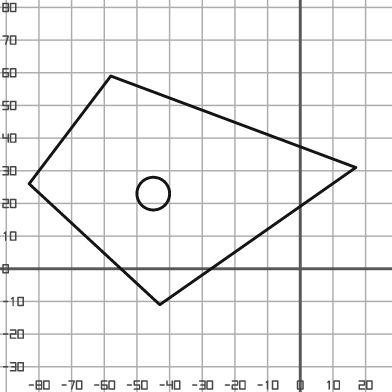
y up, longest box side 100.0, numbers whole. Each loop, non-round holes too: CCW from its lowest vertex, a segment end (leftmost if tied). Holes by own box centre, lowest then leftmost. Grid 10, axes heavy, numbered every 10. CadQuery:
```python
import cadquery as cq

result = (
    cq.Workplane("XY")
    .moveTo(-43.0, -11.0)
    .lineTo(17.0, 31.0)
    .lineTo(-58.0, 59.0)
    .lineTo(-83.0, 26.0)
    .close()
    .moveTo(-45.0, 23.0)
    .circle(5.0)
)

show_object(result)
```